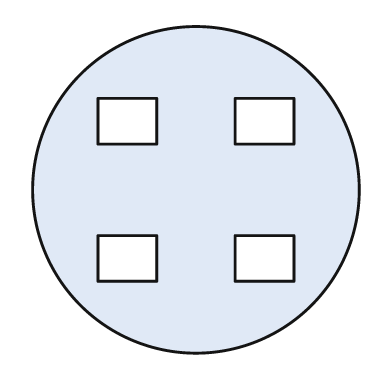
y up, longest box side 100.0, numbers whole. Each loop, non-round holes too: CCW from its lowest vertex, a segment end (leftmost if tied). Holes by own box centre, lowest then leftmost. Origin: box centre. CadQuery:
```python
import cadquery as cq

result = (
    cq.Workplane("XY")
    .moveTo(0.0, 0.0)
    .circle(50.0)
    .moveTo(-30.0, -28.0)
    .lineTo(-12.0, -28.0)
    .lineTo(-12.0, -14.0)
    .lineTo(-30.0, -14.0)
    .close()
    .moveTo(12.0, -28.0)
    .lineTo(30.0, -28.0)
    .lineTo(30.0, -14.0)
    .lineTo(12.0, -14.0)
    .close()
    .moveTo(-30.0, 14.0)
    .lineTo(-12.0, 14.0)
    .lineTo(-12.0, 28.0)
    .lineTo(-30.0, 28.0)
    .close()
    .moveTo(12.0, 14.0)
    .lineTo(30.0, 14.0)
    .lineTo(30.0, 28.0)
    .lineTo(12.0, 28.0)
    .close()
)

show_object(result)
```